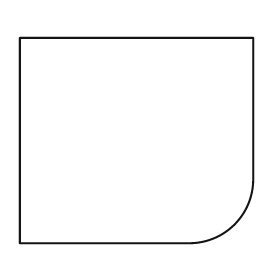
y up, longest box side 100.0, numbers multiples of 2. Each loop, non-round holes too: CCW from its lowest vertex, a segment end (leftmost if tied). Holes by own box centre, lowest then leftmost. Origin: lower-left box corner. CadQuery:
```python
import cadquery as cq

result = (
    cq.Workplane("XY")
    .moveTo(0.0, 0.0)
    .lineTo(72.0, 0.0)
    .threePointArc((92.0, 8.0), (100.0, 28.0))
    .lineTo(100.0, 88.0)
    .lineTo(0.0, 88.0)
    .close()
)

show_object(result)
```